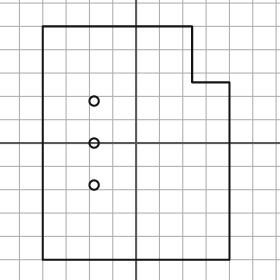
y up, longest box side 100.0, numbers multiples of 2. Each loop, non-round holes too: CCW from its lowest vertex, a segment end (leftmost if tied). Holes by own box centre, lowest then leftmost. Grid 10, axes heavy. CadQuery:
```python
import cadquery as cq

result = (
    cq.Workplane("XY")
    .moveTo(-40.0, -50.0)
    .lineTo(40.0, -50.0)
    .lineTo(40.0, 26.0)
    .lineTo(24.0, 26.0)
    .lineTo(24.0, 50.0)
    .lineTo(-40.0, 50.0)
    .close()
    .moveTo(-18.0, -18.0)
    .circle(2.0)
    .moveTo(-18.0, 0.0)
    .circle(2.0)
    .moveTo(-18.0, 18.0)
    .circle(2.0)
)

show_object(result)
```